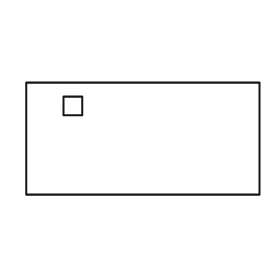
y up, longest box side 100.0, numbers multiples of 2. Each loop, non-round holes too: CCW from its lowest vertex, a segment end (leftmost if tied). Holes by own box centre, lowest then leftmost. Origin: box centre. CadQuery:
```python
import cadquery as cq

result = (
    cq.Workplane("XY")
    .moveTo(-50.0, -24.0)
    .lineTo(50.0, -24.0)
    .lineTo(50.0, 24.0)
    .lineTo(-50.0, 24.0)
    .close()
    .moveTo(-34.0, 10.0)
    .lineTo(-26.0, 10.0)
    .lineTo(-26.0, 18.0)
    .lineTo(-34.0, 18.0)
    .close()
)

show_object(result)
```